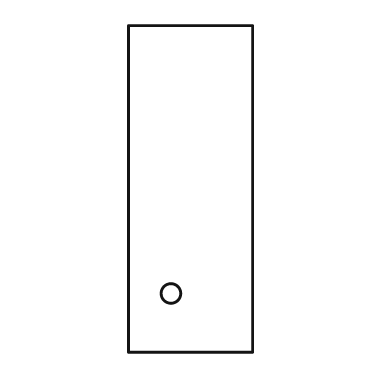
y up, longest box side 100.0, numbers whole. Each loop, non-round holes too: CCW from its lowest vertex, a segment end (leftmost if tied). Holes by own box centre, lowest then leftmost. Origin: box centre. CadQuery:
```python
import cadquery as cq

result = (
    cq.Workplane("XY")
    .moveTo(-19.0, -50.0)
    .lineTo(19.0, -50.0)
    .lineTo(19.0, 50.0)
    .lineTo(-19.0, 50.0)
    .close()
    .moveTo(-6.0, -32.0)
    .circle(3.0)
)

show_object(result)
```